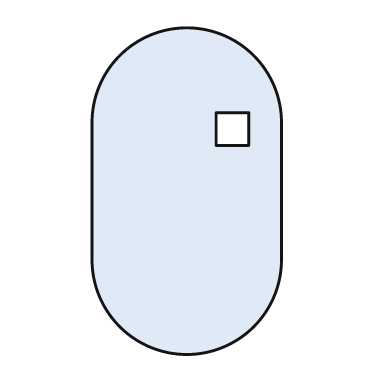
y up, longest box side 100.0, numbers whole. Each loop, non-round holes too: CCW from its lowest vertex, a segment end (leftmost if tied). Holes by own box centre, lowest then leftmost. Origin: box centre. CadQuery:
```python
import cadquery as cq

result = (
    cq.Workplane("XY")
    .moveTo(-29.0, -21.0)
    .threePointArc((0.0, -50.0), (29.0, -21.0))
    .lineTo(29.0, 21.0)
    .threePointArc((0.0, 50.0), (-29.0, 21.0))
    .close()
    .moveTo(9.0, 14.0)
    .lineTo(19.0, 14.0)
    .lineTo(19.0, 24.0)
    .lineTo(9.0, 24.0)
    .close()
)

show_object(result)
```